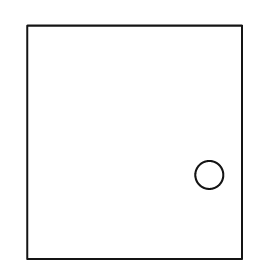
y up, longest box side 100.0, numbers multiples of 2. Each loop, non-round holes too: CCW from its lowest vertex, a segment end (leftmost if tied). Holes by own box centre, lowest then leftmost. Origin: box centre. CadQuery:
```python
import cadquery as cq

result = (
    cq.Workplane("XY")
    .moveTo(-46.0, -50.0)
    .lineTo(46.0, -50.0)
    .lineTo(46.0, 50.0)
    .lineTo(-46.0, 50.0)
    .close()
    .moveTo(32.0, -14.0)
    .circle(6.0)
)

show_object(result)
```